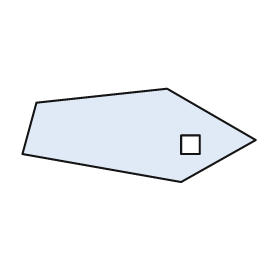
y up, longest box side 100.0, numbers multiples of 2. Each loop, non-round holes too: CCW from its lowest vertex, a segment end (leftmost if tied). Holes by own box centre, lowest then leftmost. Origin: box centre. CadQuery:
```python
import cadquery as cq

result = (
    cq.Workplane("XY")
    .moveTo(18.0, -20.0)
    .lineTo(50.0, -2.0)
    .lineTo(12.0, 20.0)
    .lineTo(-44.0, 14.0)
    .lineTo(-50.0, -8.0)
    .close()
    .moveTo(18.0, -8.0)
    .lineTo(26.0, -8.0)
    .lineTo(26.0, 0.0)
    .lineTo(18.0, 0.0)
    .close()
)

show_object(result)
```